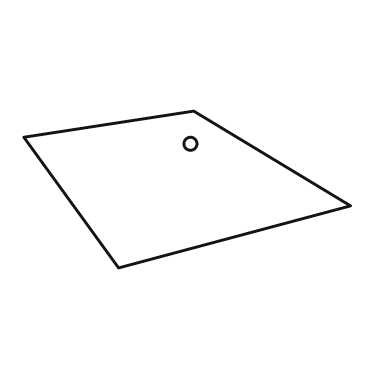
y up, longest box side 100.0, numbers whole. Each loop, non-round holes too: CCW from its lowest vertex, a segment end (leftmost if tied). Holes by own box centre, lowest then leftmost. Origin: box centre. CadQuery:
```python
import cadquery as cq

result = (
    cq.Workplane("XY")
    .moveTo(-21.0, -24.0)
    .lineTo(50.0, -5.0)
    .lineTo(2.0, 24.0)
    .lineTo(-50.0, 16.0)
    .close()
    .moveTo(1.0, 14.0)
    .circle(2.0)
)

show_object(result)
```